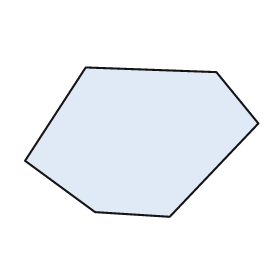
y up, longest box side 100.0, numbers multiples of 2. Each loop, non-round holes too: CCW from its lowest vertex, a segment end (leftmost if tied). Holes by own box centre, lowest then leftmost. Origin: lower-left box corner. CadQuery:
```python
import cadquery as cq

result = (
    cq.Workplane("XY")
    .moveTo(62.0, 0.0)
    .lineTo(100.0, 40.0)
    .lineTo(82.0, 62.0)
    .lineTo(26.0, 64.0)
    .lineTo(0.0, 24.0)
    .lineTo(30.0, 2.0)
    .close()
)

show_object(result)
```